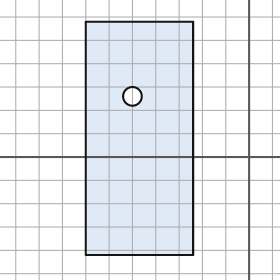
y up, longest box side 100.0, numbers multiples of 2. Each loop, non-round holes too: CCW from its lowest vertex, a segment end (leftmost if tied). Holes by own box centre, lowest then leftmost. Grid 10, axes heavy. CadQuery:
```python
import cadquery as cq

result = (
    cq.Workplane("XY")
    .moveTo(-70.0, -42.0)
    .lineTo(-24.0, -42.0)
    .lineTo(-24.0, 58.0)
    .lineTo(-70.0, 58.0)
    .close()
    .moveTo(-50.0, 26.0)
    .circle(4.0)
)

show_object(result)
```